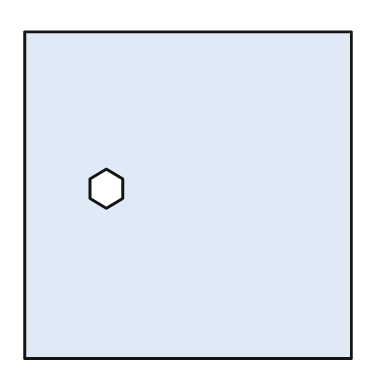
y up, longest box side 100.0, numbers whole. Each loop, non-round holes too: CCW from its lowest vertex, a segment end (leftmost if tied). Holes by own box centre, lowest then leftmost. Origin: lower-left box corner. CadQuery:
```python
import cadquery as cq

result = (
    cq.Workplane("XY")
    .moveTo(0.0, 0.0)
    .lineTo(100.0, 0.0)
    .lineTo(100.0, 100.0)
    .lineTo(0.0, 100.0)
    .close()
    .moveTo(25.0, 46.0)
    .lineTo(30.0, 49.0)
    .lineTo(30.0, 55.0)
    .lineTo(25.0, 58.0)
    .lineTo(20.0, 55.0)
    .lineTo(20.0, 49.0)
    .close()
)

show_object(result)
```